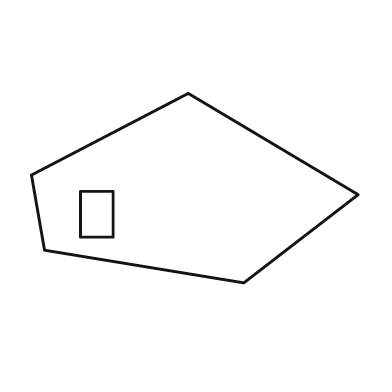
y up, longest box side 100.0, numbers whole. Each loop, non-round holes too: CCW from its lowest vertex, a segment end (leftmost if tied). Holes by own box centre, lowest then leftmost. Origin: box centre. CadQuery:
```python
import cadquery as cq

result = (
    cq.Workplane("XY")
    .moveTo(15.0, -29.0)
    .lineTo(50.0, -2.0)
    .lineTo(-2.0, 29.0)
    .lineTo(-50.0, 4.0)
    .lineTo(-46.0, -19.0)
    .close()
    .moveTo(-35.0, -15.0)
    .lineTo(-25.0, -15.0)
    .lineTo(-25.0, -1.0)
    .lineTo(-35.0, -1.0)
    .close()
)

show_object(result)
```